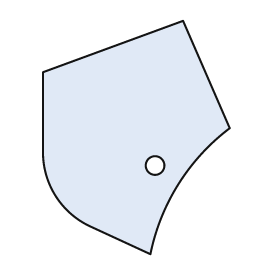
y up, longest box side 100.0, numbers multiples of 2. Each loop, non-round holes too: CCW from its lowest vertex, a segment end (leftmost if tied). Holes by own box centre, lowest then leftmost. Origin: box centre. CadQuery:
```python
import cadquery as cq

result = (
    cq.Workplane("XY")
    .moveTo(6.0, -50.0)
    .threePointArc((18.0, -20.0), (40.0, 4.0))
    .lineTo(20.0, 50.0)
    .lineTo(-40.0, 28.0)
    .lineTo(-40.0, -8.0)
    .threePointArc((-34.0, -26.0), (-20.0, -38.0))
    .close()
    .moveTo(8.0, -12.0)
    .circle(4.0)
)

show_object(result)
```